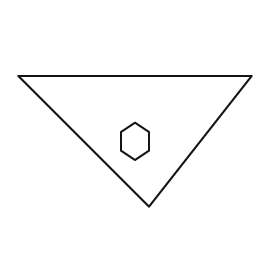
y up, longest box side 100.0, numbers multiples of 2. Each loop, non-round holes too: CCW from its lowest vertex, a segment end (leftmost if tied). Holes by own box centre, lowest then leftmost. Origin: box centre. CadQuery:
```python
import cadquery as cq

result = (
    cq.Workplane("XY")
    .moveTo(6.0, -28.0)
    .lineTo(50.0, 28.0)
    .lineTo(-50.0, 28.0)
    .close()
    .moveTo(0.0, -8.0)
    .lineTo(6.0, -4.0)
    .lineTo(6.0, 4.0)
    .lineTo(0.0, 8.0)
    .lineTo(-6.0, 4.0)
    .lineTo(-6.0, -4.0)
    .close()
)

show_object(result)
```